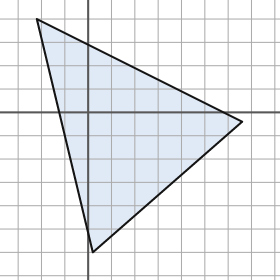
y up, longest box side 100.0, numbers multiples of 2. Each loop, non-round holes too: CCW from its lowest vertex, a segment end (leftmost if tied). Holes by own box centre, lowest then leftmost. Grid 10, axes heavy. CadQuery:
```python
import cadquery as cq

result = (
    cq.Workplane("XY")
    .moveTo(2.0, -60.0)
    .lineTo(66.0, -4.0)
    .lineTo(-22.0, 40.0)
    .close()
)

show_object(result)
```